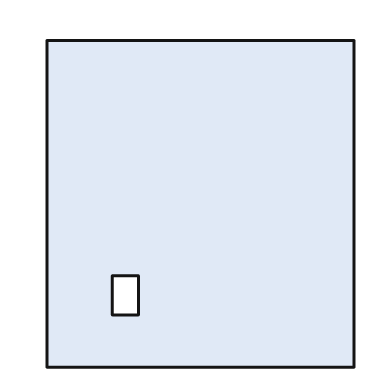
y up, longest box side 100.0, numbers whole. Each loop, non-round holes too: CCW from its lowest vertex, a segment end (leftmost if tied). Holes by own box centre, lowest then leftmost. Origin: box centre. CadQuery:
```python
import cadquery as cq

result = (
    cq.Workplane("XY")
    .moveTo(-47.0, -50.0)
    .lineTo(47.0, -50.0)
    .lineTo(47.0, 50.0)
    .lineTo(-47.0, 50.0)
    .close()
    .moveTo(-27.0, -34.0)
    .lineTo(-19.0, -34.0)
    .lineTo(-19.0, -22.0)
    .lineTo(-27.0, -22.0)
    .close()
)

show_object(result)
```